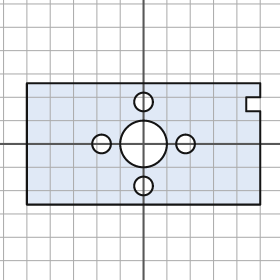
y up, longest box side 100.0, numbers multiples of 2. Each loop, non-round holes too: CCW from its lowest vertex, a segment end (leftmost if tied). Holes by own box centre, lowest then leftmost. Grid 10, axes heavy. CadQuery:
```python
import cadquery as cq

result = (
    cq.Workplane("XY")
    .moveTo(-50.0, -26.0)
    .lineTo(50.0, -26.0)
    .lineTo(50.0, 14.0)
    .lineTo(44.0, 14.0)
    .lineTo(44.0, 20.0)
    .lineTo(50.0, 20.0)
    .lineTo(50.0, 26.0)
    .lineTo(-50.0, 26.0)
    .close()
    .moveTo(0.0, -18.0)
    .circle(4.0)
    .moveTo(-18.0, 0.0)
    .circle(4.0)
    .moveTo(0.0, 0.0)
    .circle(10.0)
    .moveTo(18.0, 0.0)
    .circle(4.0)
    .moveTo(0.0, 18.0)
    .circle(4.0)
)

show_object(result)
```